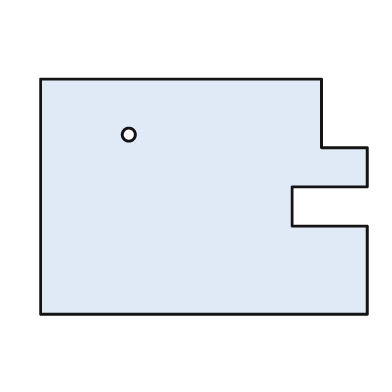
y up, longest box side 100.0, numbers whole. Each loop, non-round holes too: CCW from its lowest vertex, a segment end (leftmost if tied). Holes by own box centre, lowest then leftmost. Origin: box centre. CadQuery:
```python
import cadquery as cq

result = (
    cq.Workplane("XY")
    .moveTo(-50.0, -36.0)
    .lineTo(50.0, -36.0)
    .lineTo(50.0, -9.0)
    .lineTo(27.0, -9.0)
    .lineTo(27.0, 3.0)
    .lineTo(50.0, 3.0)
    .lineTo(50.0, 15.0)
    .lineTo(36.0, 15.0)
    .lineTo(36.0, 36.0)
    .lineTo(-50.0, 36.0)
    .close()
    .moveTo(-23.0, 19.0)
    .circle(2.0)
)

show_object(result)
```